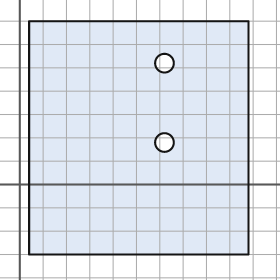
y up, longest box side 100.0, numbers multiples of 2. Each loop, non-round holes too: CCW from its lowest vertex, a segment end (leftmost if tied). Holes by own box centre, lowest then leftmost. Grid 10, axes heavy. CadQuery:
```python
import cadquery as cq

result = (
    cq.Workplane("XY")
    .moveTo(4.0, -30.0)
    .lineTo(98.0, -30.0)
    .lineTo(98.0, 70.0)
    .lineTo(4.0, 70.0)
    .close()
    .moveTo(62.0, 18.0)
    .circle(4.0)
    .moveTo(62.0, 52.0)
    .circle(4.0)
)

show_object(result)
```